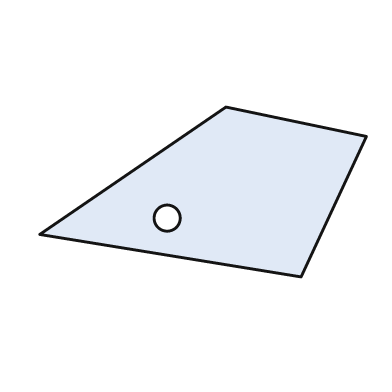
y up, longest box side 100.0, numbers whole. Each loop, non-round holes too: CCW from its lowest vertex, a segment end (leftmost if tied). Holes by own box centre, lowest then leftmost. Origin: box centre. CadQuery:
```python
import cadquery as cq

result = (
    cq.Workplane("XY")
    .moveTo(30.0, -26.0)
    .lineTo(50.0, 17.0)
    .lineTo(7.0, 26.0)
    .lineTo(-50.0, -13.0)
    .close()
    .moveTo(-11.0, -8.0)
    .circle(4.0)
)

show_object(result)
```